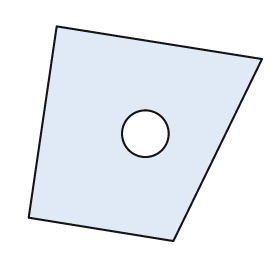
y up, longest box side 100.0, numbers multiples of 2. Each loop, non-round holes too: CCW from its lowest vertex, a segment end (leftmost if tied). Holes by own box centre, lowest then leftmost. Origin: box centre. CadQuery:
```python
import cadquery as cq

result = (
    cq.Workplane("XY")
    .moveTo(12.0, -46.0)
    .lineTo(50.0, 32.0)
    .lineTo(-38.0, 46.0)
    .lineTo(-50.0, -36.0)
    .close()
    .moveTo(0.0, 0.0)
    .circle(10.0)
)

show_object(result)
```